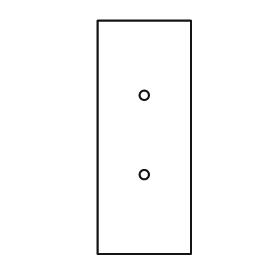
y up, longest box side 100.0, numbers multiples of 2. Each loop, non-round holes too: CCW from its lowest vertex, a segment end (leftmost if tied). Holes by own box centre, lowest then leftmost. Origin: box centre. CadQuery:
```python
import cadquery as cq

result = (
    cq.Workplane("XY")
    .moveTo(-20.0, -50.0)
    .lineTo(20.0, -50.0)
    .lineTo(20.0, 50.0)
    .lineTo(-20.0, 50.0)
    .close()
    .moveTo(0.0, -16.0)
    .circle(2.0)
    .moveTo(0.0, 18.0)
    .circle(2.0)
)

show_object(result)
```